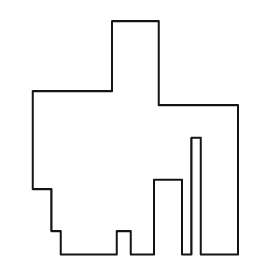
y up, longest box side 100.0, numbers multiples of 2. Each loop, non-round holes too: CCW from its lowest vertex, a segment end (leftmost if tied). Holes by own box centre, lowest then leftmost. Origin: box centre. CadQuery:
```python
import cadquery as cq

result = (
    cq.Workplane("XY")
    .moveTo(-32.0, -50.0)
    .lineTo(-8.0, -50.0)
    .lineTo(-8.0, -40.0)
    .lineTo(-2.0, -40.0)
    .lineTo(-2.0, -50.0)
    .lineTo(8.0, -50.0)
    .lineTo(8.0, -18.0)
    .lineTo(20.0, -18.0)
    .lineTo(20.0, -50.0)
    .lineTo(24.0, -50.0)
    .lineTo(24.0, 0.0)
    .lineTo(28.0, 0.0)
    .lineTo(28.0, -50.0)
    .lineTo(44.0, -50.0)
    .lineTo(44.0, 14.0)
    .lineTo(10.0, 14.0)
    .lineTo(10.0, 50.0)
    .lineTo(-10.0, 50.0)
    .lineTo(-10.0, 20.0)
    .lineTo(-44.0, 20.0)
    .lineTo(-44.0, -22.0)
    .lineTo(-36.0, -22.0)
    .lineTo(-36.0, -40.0)
    .lineTo(-32.0, -40.0)
    .close()
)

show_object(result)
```